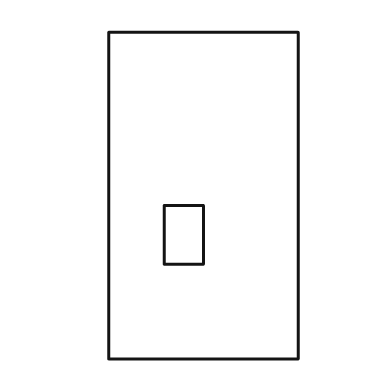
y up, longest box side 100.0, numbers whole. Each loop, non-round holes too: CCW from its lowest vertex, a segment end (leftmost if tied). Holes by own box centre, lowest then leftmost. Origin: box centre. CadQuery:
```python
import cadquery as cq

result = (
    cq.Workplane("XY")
    .moveTo(-29.0, -50.0)
    .lineTo(29.0, -50.0)
    .lineTo(29.0, 50.0)
    .lineTo(-29.0, 50.0)
    .close()
    .moveTo(-12.0, -21.0)
    .lineTo(0.0, -21.0)
    .lineTo(0.0, -3.0)
    .lineTo(-12.0, -3.0)
    .close()
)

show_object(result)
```